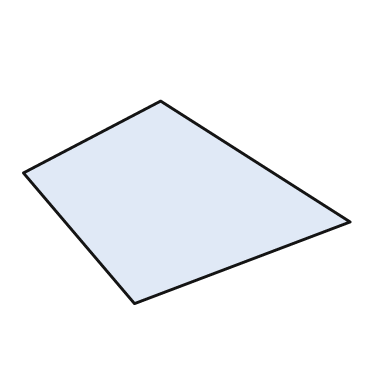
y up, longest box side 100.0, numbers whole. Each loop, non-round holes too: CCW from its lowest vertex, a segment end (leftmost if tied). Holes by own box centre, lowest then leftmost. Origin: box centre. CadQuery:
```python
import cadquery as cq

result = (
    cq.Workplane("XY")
    .moveTo(-16.0, -31.0)
    .lineTo(50.0, -6.0)
    .lineTo(-8.0, 31.0)
    .lineTo(-50.0, 9.0)
    .close()
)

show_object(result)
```